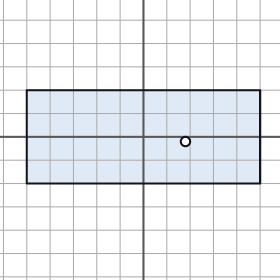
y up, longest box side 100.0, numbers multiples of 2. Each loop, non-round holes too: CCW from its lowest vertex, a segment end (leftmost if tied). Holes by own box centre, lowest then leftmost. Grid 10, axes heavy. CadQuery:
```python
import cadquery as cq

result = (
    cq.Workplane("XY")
    .moveTo(-50.0, -20.0)
    .lineTo(50.0, -20.0)
    .lineTo(50.0, 20.0)
    .lineTo(-50.0, 20.0)
    .close()
    .moveTo(18.0, -2.0)
    .circle(2.0)
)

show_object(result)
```